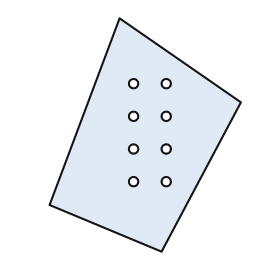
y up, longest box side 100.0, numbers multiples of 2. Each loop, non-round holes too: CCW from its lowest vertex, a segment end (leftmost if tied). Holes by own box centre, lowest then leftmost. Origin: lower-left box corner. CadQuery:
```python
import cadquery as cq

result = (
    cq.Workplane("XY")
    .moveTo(48.0, 0.0)
    .lineTo(82.0, 64.0)
    .lineTo(30.0, 100.0)
    .lineTo(0.0, 20.0)
    .close()
    .moveTo(36.0, 30.0)
    .circle(2.0)
    .moveTo(50.0, 30.0)
    .circle(2.0)
    .moveTo(36.0, 44.0)
    .circle(2.0)
    .moveTo(50.0, 44.0)
    .circle(2.0)
    .moveTo(36.0, 58.0)
    .circle(2.0)
    .moveTo(50.0, 58.0)
    .circle(2.0)
    .moveTo(36.0, 72.0)
    .circle(2.0)
    .moveTo(50.0, 72.0)
    .circle(2.0)
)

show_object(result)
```